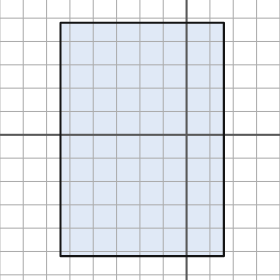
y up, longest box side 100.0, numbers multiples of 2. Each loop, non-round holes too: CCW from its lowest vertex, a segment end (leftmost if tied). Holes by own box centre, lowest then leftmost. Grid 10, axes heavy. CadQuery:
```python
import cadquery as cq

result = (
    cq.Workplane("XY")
    .moveTo(-54.0, -52.0)
    .lineTo(16.0, -52.0)
    .lineTo(16.0, 48.0)
    .lineTo(-54.0, 48.0)
    .close()
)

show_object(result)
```